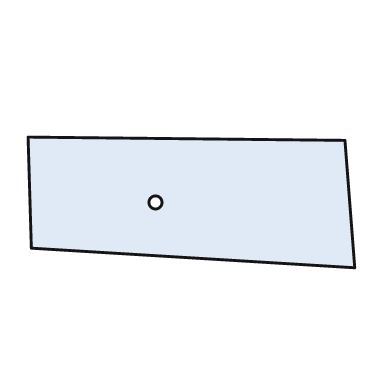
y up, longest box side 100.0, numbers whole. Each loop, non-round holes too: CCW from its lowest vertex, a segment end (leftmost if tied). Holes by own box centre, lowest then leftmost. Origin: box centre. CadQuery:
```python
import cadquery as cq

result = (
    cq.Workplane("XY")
    .moveTo(50.0, -20.0)
    .lineTo(47.0, 19.0)
    .lineTo(-50.0, 20.0)
    .lineTo(-49.0, -14.0)
    .close()
    .moveTo(-11.0, 0.0)
    .circle(2.0)
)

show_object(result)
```